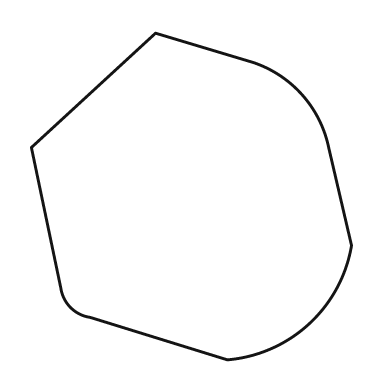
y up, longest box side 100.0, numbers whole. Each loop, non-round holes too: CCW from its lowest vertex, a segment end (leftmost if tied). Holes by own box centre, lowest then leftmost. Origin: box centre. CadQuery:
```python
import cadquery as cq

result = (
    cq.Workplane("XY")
    .moveTo(11.0, -50.0)
    .threePointArc((36.0, -39.0), (49.0, -15.0))
    .lineTo(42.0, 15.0)
    .threePointArc((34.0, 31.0), (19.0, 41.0))
    .lineTo(-11.0, 50.0)
    .lineTo(-49.0, 15.0)
    .lineTo(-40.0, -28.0)
    .threePointArc((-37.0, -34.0), (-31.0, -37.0))
    .close()
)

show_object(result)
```